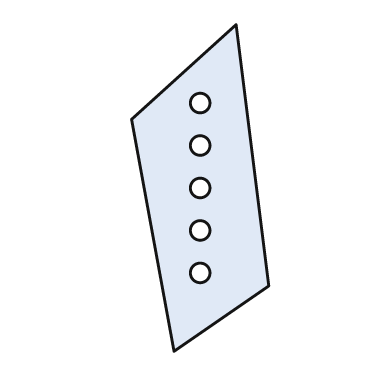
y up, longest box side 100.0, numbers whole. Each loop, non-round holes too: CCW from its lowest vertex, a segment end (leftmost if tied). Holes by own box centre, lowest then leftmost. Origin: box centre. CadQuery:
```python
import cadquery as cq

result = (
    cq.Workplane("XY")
    .moveTo(-8.0, -50.0)
    .lineTo(21.0, -30.0)
    .lineTo(11.0, 50.0)
    .lineTo(-21.0, 21.0)
    .close()
    .moveTo(0.0, -26.0)
    .circle(3.0)
    .moveTo(0.0, -13.0)
    .circle(3.0)
    .moveTo(0.0, 0.0)
    .circle(3.0)
    .moveTo(0.0, 13.0)
    .circle(3.0)
    .moveTo(0.0, 26.0)
    .circle(3.0)
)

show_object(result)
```